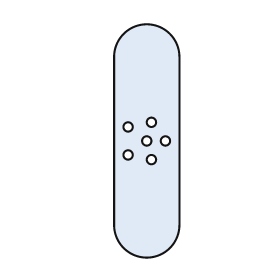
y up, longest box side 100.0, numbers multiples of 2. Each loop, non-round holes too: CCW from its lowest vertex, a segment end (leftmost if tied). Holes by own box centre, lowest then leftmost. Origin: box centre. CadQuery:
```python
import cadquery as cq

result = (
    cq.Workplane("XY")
    .moveTo(-14.0, -36.0)
    .threePointArc((0.0, -50.0), (14.0, -36.0))
    .lineTo(14.0, 36.0)
    .threePointArc((0.0, 50.0), (-14.0, 36.0))
    .close()
    .moveTo(2.0, -8.0)
    .circle(2.0)
    .moveTo(-8.0, -6.0)
    .circle(2.0)
    .moveTo(0.0, 0.0)
    .circle(2.0)
    .moveTo(8.0, 0.0)
    .circle(2.0)
    .moveTo(-8.0, 6.0)
    .circle(2.0)
    .moveTo(2.0, 8.0)
    .circle(2.0)
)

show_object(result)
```